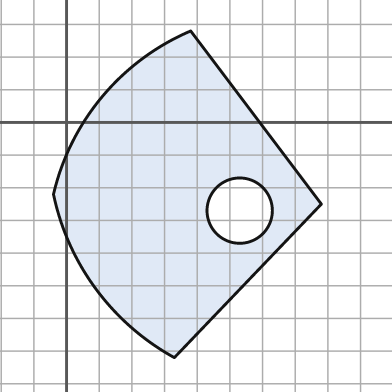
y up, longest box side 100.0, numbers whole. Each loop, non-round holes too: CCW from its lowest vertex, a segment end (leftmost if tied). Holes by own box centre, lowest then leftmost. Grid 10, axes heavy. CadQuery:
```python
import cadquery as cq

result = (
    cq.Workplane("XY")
    .moveTo(33.0, -72.0)
    .lineTo(78.0, -25.0)
    .lineTo(38.0, 28.0)
    .threePointArc((11.0, 8.0), (-4.0, -22.0))
    .threePointArc((9.0, -51.0), (33.0, -72.0))
    .close()
    .moveTo(53.0, -27.0)
    .circle(10.0)
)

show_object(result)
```